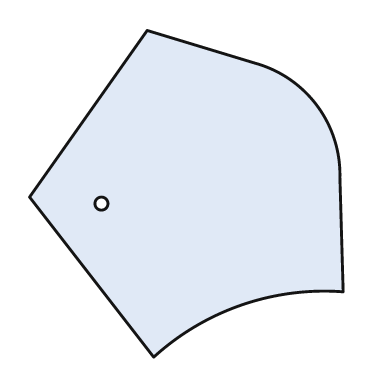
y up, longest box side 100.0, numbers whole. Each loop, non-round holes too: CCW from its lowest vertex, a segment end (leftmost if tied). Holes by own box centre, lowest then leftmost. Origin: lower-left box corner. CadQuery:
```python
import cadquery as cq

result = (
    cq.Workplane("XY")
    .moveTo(38.0, 0.0)
    .threePointArc((65.0, 16.0), (96.0, 20.0))
    .lineTo(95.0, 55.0)
    .threePointArc((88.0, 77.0), (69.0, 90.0))
    .lineTo(36.0, 100.0)
    .lineTo(0.0, 49.0)
    .close()
    .moveTo(22.0, 47.0)
    .circle(2.0)
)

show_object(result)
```